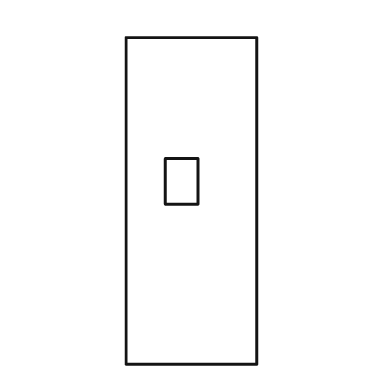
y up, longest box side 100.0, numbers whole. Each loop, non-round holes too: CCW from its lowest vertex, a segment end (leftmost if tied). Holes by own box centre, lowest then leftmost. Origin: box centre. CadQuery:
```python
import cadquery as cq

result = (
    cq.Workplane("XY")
    .moveTo(-20.0, -50.0)
    .lineTo(20.0, -50.0)
    .lineTo(20.0, 50.0)
    .lineTo(-20.0, 50.0)
    .close()
    .moveTo(-8.0, -1.0)
    .lineTo(2.0, -1.0)
    .lineTo(2.0, 13.0)
    .lineTo(-8.0, 13.0)
    .close()
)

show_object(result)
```